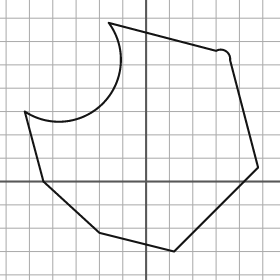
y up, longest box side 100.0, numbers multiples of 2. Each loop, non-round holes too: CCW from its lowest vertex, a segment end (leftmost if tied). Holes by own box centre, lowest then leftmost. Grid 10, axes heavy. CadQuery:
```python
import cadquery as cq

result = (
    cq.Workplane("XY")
    .moveTo(12.0, -30.0)
    .lineTo(48.0, 6.0)
    .lineTo(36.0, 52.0)
    .threePointArc((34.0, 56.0), (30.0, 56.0))
    .lineTo(-16.0, 68.0)
    .threePointArc((-18.0, 34.0), (-52.0, 30.0))
    .lineTo(-44.0, 0.0)
    .lineTo(-20.0, -22.0)
    .close()
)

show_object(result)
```